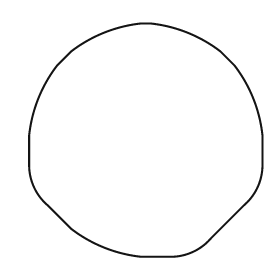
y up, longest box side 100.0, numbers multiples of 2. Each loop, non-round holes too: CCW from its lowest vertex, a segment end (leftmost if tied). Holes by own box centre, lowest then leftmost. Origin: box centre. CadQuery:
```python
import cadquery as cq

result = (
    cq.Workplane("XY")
    .moveTo(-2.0, -50.0)
    .lineTo(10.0, -50.0)
    .threePointArc((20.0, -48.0), (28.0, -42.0))
    .lineTo(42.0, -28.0)
    .threePointArc((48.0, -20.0), (50.0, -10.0))
    .lineTo(50.0, 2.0)
    .threePointArc((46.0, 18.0), (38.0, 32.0))
    .lineTo(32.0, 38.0)
    .threePointArc((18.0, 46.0), (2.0, 50.0))
    .lineTo(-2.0, 50.0)
    .threePointArc((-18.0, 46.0), (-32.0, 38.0))
    .lineTo(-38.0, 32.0)
    .threePointArc((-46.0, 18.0), (-50.0, 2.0))
    .lineTo(-50.0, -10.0)
    .threePointArc((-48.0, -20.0), (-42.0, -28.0))
    .lineTo(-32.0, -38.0)
    .threePointArc((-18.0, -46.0), (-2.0, -50.0))
    .close()
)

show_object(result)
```